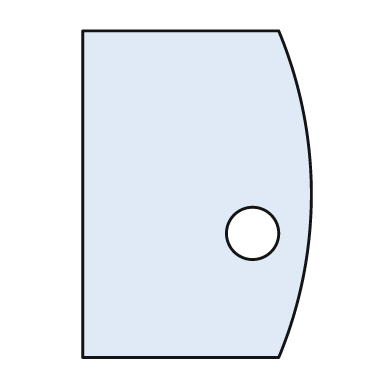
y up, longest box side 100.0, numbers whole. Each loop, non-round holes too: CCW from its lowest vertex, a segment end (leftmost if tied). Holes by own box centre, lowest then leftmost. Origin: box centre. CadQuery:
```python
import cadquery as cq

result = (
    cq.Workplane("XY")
    .moveTo(-35.0, -50.0)
    .lineTo(25.0, -50.0)
    .threePointArc((35.0, 0.0), (25.0, 50.0))
    .lineTo(-35.0, 50.0)
    .close()
    .moveTo(17.0, -12.0)
    .circle(8.0)
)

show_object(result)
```